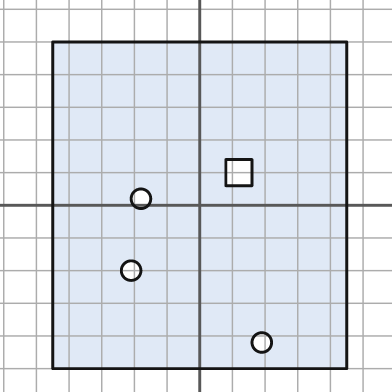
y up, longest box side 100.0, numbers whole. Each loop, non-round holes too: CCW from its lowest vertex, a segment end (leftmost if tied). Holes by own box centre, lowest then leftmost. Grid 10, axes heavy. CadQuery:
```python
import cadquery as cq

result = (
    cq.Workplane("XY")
    .moveTo(-45.0, -50.0)
    .lineTo(45.0, -50.0)
    .lineTo(45.0, 50.0)
    .lineTo(-45.0, 50.0)
    .close()
    .moveTo(19.0, -42.0)
    .circle(3.0)
    .moveTo(-21.0, -20.0)
    .circle(3.0)
    .moveTo(-18.0, 2.0)
    .circle(3.0)
    .moveTo(8.0, 6.0)
    .lineTo(16.0, 6.0)
    .lineTo(16.0, 14.0)
    .lineTo(8.0, 14.0)
    .close()
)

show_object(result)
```